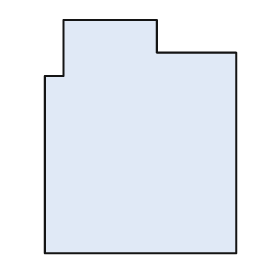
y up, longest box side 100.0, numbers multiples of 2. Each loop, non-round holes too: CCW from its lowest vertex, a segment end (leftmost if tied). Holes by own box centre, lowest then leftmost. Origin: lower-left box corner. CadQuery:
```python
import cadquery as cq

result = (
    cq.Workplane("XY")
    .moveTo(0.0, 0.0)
    .lineTo(82.0, 0.0)
    .lineTo(82.0, 86.0)
    .lineTo(48.0, 86.0)
    .lineTo(48.0, 100.0)
    .lineTo(8.0, 100.0)
    .lineTo(8.0, 76.0)
    .lineTo(0.0, 76.0)
    .close()
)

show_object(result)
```